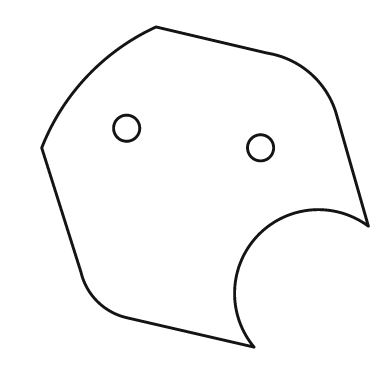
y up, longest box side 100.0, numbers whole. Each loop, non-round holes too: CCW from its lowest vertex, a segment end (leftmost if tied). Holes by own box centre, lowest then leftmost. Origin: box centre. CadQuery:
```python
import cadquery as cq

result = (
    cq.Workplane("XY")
    .moveTo(15.0, -49.0)
    .threePointArc((16.0, -15.0), (50.0, -12.0))
    .lineTo(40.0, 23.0)
    .threePointArc((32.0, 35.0), (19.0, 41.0))
    .lineTo(-15.0, 49.0)
    .threePointArc((-36.0, 34.0), (-50.0, 12.0))
    .lineTo(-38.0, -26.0)
    .threePointArc((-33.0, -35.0), (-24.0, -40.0))
    .close()
    .moveTo(17.0, 12.0)
    .circle(4.0)
    .moveTo(-24.0, 18.0)
    .circle(4.0)
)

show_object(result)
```